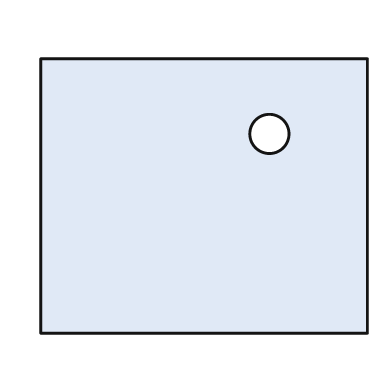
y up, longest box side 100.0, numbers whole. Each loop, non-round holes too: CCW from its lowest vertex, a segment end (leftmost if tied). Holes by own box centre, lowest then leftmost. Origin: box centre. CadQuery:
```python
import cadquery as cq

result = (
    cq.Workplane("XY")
    .moveTo(-50.0, -42.0)
    .lineTo(50.0, -42.0)
    .lineTo(50.0, 42.0)
    .lineTo(-50.0, 42.0)
    .close()
    .moveTo(20.0, 19.0)
    .circle(6.0)
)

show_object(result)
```